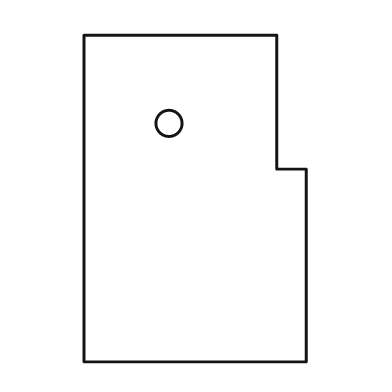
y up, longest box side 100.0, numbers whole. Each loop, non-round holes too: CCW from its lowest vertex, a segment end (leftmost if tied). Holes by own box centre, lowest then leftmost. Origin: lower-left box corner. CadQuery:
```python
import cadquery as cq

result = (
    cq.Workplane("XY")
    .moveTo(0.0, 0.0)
    .lineTo(68.0, 0.0)
    .lineTo(68.0, 59.0)
    .lineTo(59.0, 59.0)
    .lineTo(59.0, 100.0)
    .lineTo(0.0, 100.0)
    .close()
    .moveTo(26.0, 73.0)
    .circle(4.0)
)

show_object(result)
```